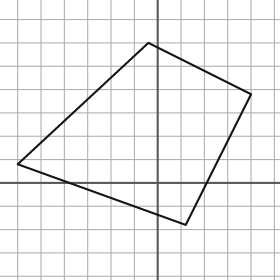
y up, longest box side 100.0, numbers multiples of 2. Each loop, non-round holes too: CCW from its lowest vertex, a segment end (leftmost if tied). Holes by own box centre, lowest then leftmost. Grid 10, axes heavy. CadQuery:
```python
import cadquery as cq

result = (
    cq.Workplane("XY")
    .moveTo(12.0, -18.0)
    .lineTo(40.0, 38.0)
    .lineTo(-4.0, 60.0)
    .lineTo(-60.0, 8.0)
    .close()
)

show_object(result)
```